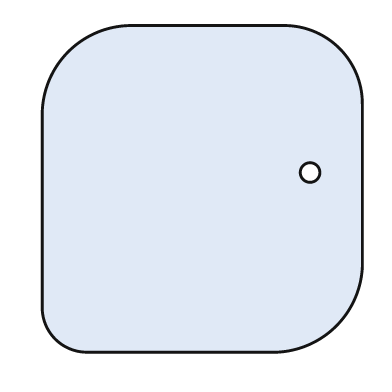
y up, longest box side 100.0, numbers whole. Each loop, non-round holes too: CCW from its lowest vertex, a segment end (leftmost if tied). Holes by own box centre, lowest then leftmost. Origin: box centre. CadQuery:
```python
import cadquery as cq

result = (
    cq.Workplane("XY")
    .moveTo(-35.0, -50.0)
    .lineTo(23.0, -50.0)
    .threePointArc((41.0, -42.0), (49.0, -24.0))
    .lineTo(49.0, 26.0)
    .threePointArc((42.0, 43.0), (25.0, 50.0))
    .lineTo(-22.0, 50.0)
    .threePointArc((-41.0, 42.0), (-49.0, 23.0))
    .lineTo(-49.0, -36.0)
    .threePointArc((-45.0, -46.0), (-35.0, -50.0))
    .close()
    .moveTo(33.0, 5.0)
    .circle(3.0)
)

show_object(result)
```